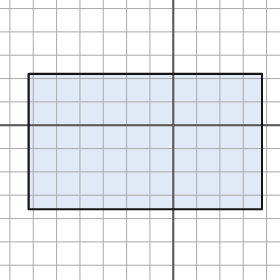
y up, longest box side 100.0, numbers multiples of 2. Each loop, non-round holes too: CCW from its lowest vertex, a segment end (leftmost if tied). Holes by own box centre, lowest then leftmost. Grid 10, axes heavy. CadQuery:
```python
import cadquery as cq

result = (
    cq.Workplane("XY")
    .moveTo(-62.0, -36.0)
    .lineTo(38.0, -36.0)
    .lineTo(38.0, 22.0)
    .lineTo(-62.0, 22.0)
    .close()
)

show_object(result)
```